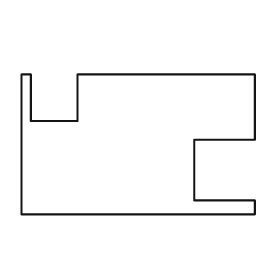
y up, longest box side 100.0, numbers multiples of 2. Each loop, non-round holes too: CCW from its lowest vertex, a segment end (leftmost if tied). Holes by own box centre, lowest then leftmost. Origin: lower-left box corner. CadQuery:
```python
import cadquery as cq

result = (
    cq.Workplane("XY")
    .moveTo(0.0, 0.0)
    .lineTo(100.0, 0.0)
    .lineTo(100.0, 6.0)
    .lineTo(74.0, 6.0)
    .lineTo(74.0, 32.0)
    .lineTo(100.0, 32.0)
    .lineTo(100.0, 60.0)
    .lineTo(24.0, 60.0)
    .lineTo(24.0, 40.0)
    .lineTo(4.0, 40.0)
    .lineTo(4.0, 60.0)
    .lineTo(0.0, 60.0)
    .close()
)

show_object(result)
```